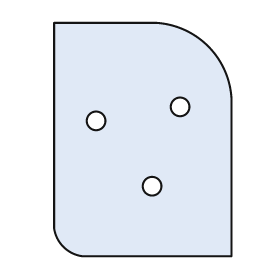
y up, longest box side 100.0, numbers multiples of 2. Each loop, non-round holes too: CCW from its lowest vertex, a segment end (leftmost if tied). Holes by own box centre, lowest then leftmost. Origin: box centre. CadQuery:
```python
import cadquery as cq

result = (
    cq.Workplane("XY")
    .moveTo(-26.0, -50.0)
    .lineTo(38.0, -50.0)
    .lineTo(38.0, 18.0)
    .threePointArc((28.0, 40.0), (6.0, 50.0))
    .lineTo(-38.0, 50.0)
    .lineTo(-38.0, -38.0)
    .threePointArc((-34.0, -46.0), (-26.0, -50.0))
    .close()
    .moveTo(4.0, -20.0)
    .circle(4.0)
    .moveTo(-20.0, 8.0)
    .circle(4.0)
    .moveTo(16.0, 14.0)
    .circle(4.0)
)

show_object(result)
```